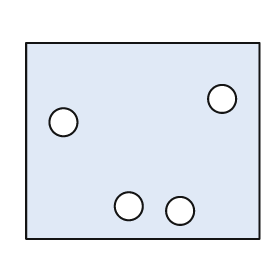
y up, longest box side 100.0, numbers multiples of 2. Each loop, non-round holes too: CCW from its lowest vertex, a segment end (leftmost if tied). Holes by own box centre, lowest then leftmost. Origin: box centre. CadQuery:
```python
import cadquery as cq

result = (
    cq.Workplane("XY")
    .moveTo(-50.0, -42.0)
    .lineTo(50.0, -42.0)
    .lineTo(50.0, 42.0)
    .lineTo(-50.0, 42.0)
    .close()
    .moveTo(16.0, -30.0)
    .circle(6.0)
    .moveTo(-6.0, -28.0)
    .circle(6.0)
    .moveTo(-34.0, 8.0)
    .circle(6.0)
    .moveTo(34.0, 18.0)
    .circle(6.0)
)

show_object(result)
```